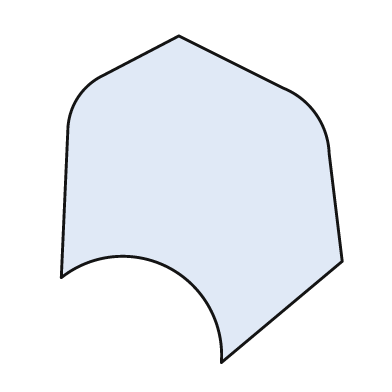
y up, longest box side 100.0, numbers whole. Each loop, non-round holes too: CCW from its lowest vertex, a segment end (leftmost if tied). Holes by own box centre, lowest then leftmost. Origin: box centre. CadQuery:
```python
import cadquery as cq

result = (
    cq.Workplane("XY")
    .moveTo(6.0, -50.0)
    .lineTo(43.0, -19.0)
    .lineTo(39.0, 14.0)
    .threePointArc((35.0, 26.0), (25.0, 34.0))
    .lineTo(-7.0, 50.0)
    .lineTo(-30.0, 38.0)
    .threePointArc((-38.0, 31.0), (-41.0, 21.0))
    .lineTo(-43.0, -24.0)
    .threePointArc((-10.0, -21.0), (6.0, -50.0))
    .close()
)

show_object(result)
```